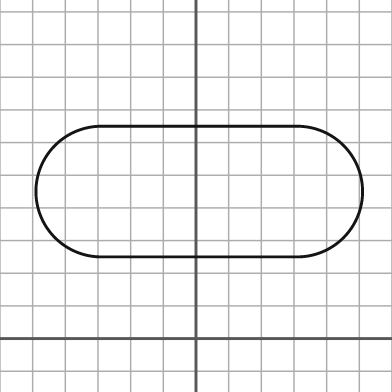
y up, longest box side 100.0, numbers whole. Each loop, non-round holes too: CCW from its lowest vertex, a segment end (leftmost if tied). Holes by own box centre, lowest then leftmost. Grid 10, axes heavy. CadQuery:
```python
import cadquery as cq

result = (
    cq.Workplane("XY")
    .moveTo(-29.0, 25.0)
    .lineTo(31.0, 25.0)
    .threePointArc((51.0, 45.0), (31.0, 65.0))
    .lineTo(-29.0, 65.0)
    .threePointArc((-49.0, 45.0), (-29.0, 25.0))
    .close()
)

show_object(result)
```